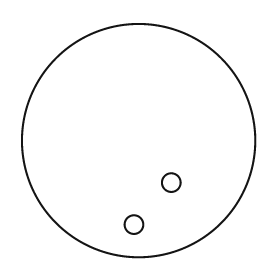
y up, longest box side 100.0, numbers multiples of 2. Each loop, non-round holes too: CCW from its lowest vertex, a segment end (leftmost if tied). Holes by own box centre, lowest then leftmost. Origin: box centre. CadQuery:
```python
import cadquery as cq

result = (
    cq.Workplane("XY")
    .moveTo(0.0, 0.0)
    .circle(50.0)
    .moveTo(-2.0, -36.0)
    .circle(4.0)
    .moveTo(14.0, -18.0)
    .circle(4.0)
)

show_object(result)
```